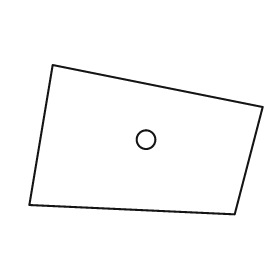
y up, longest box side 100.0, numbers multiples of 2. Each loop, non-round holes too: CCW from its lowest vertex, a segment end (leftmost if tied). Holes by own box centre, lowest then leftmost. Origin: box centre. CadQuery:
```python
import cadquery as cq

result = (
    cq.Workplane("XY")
    .moveTo(38.0, -32.0)
    .lineTo(50.0, 14.0)
    .lineTo(-40.0, 32.0)
    .lineTo(-50.0, -28.0)
    .close()
    .moveTo(0.0, 0.0)
    .circle(4.0)
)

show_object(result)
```